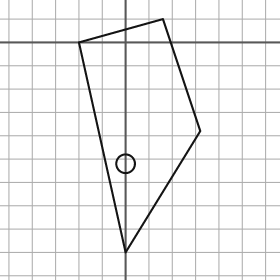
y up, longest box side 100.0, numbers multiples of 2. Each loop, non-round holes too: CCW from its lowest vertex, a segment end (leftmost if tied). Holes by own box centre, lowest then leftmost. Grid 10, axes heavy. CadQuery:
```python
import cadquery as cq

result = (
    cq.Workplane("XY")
    .moveTo(0.0, -90.0)
    .lineTo(32.0, -38.0)
    .lineTo(16.0, 10.0)
    .lineTo(-20.0, 0.0)
    .close()
    .moveTo(0.0, -52.0)
    .circle(4.0)
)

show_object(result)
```